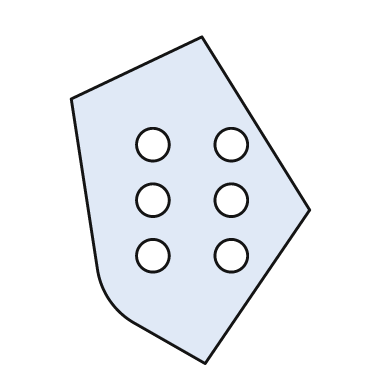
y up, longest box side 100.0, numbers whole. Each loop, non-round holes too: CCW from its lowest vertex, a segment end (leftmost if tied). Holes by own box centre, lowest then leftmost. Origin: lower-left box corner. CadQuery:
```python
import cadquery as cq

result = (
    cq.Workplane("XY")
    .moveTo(41.0, 0.0)
    .lineTo(73.0, 47.0)
    .lineTo(40.0, 100.0)
    .lineTo(0.0, 81.0)
    .lineTo(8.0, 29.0)
    .threePointArc((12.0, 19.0), (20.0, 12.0))
    .close()
    .moveTo(25.0, 33.0)
    .circle(5.0)
    .moveTo(49.0, 33.0)
    .circle(5.0)
    .moveTo(25.0, 50.0)
    .circle(5.0)
    .moveTo(49.0, 50.0)
    .circle(5.0)
    .moveTo(25.0, 67.0)
    .circle(5.0)
    .moveTo(49.0, 67.0)
    .circle(5.0)
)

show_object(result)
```